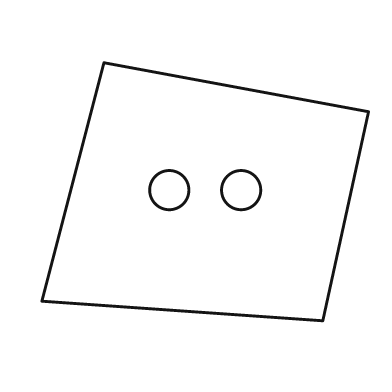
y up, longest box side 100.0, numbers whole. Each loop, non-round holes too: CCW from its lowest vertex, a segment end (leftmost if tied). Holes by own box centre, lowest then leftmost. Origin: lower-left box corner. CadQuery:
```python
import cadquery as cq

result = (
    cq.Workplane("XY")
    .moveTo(86.0, 0.0)
    .lineTo(100.0, 64.0)
    .lineTo(19.0, 79.0)
    .lineTo(0.0, 6.0)
    .close()
    .moveTo(39.0, 40.0)
    .circle(6.0)
    .moveTo(61.0, 40.0)
    .circle(6.0)
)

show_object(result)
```